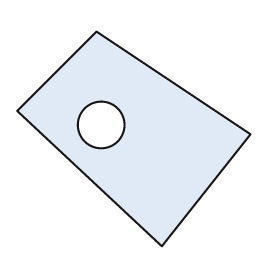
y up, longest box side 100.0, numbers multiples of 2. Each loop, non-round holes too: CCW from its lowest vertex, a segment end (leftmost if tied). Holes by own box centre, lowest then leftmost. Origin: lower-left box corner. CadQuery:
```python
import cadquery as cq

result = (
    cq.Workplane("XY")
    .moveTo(62.0, 0.0)
    .lineTo(100.0, 48.0)
    .lineTo(34.0, 92.0)
    .lineTo(0.0, 58.0)
    .close()
    .moveTo(36.0, 52.0)
    .circle(10.0)
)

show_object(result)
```